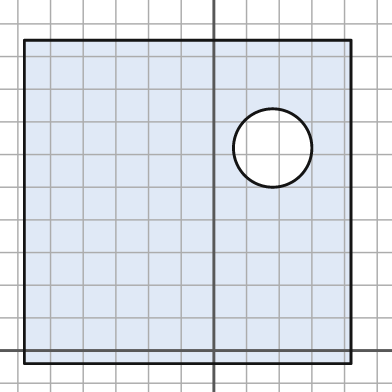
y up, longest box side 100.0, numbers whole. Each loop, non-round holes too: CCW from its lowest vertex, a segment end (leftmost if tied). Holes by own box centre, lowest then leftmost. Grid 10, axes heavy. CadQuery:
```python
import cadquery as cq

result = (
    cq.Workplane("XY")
    .moveTo(-58.0, -4.0)
    .lineTo(42.0, -4.0)
    .lineTo(42.0, 95.0)
    .lineTo(-58.0, 95.0)
    .close()
    .moveTo(18.0, 62.0)
    .circle(12.0)
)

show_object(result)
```